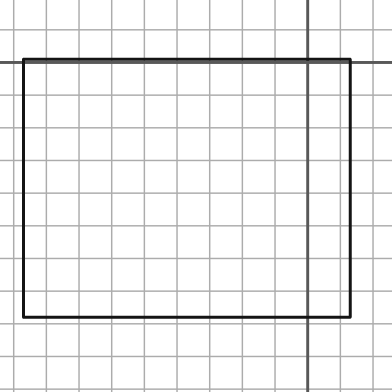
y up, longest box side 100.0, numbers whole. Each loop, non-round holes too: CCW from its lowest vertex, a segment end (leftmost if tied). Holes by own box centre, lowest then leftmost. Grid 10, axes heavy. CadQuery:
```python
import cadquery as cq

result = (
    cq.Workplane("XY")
    .moveTo(-87.0, -78.0)
    .lineTo(13.0, -78.0)
    .lineTo(13.0, 1.0)
    .lineTo(-87.0, 1.0)
    .close()
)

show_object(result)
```